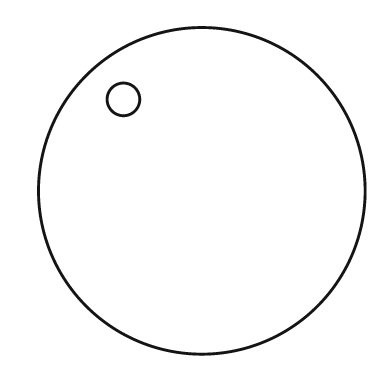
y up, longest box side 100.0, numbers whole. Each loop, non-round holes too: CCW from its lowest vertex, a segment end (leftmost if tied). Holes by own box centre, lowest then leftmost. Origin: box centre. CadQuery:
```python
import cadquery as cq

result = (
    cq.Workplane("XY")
    .moveTo(0.0, 0.0)
    .circle(50.0)
    .moveTo(-24.0, 28.0)
    .circle(5.0)
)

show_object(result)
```